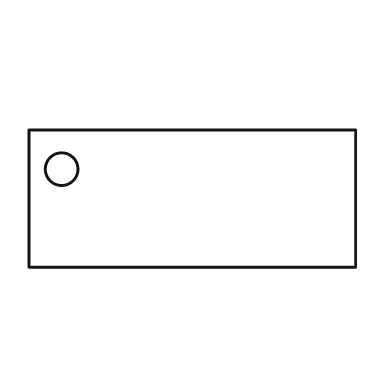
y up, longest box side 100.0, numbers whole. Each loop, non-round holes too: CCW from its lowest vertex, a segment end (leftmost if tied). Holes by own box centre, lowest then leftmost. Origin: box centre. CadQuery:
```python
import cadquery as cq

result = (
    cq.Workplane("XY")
    .moveTo(-50.0, -21.0)
    .lineTo(50.0, -21.0)
    .lineTo(50.0, 21.0)
    .lineTo(-50.0, 21.0)
    .close()
    .moveTo(-40.0, 9.0)
    .circle(5.0)
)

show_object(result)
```